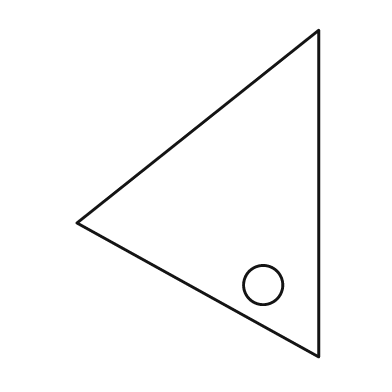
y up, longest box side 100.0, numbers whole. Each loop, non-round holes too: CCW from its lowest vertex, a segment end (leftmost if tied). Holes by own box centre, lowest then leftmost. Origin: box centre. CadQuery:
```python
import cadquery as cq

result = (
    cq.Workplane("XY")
    .moveTo(37.0, -50.0)
    .lineTo(37.0, 50.0)
    .lineTo(-37.0, -9.0)
    .close()
    .moveTo(20.0, -28.0)
    .circle(6.0)
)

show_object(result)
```